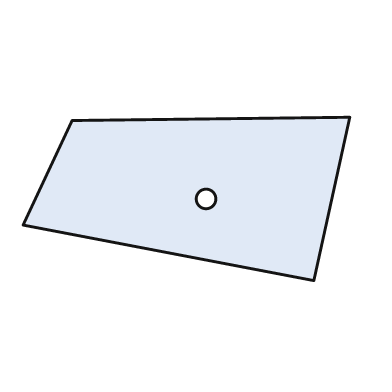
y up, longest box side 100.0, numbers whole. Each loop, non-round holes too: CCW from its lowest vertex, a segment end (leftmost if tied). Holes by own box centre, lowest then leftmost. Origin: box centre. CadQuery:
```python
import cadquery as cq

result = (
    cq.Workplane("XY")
    .moveTo(39.0, -25.0)
    .lineTo(50.0, 25.0)
    .lineTo(-35.0, 24.0)
    .lineTo(-50.0, -8.0)
    .close()
    .moveTo(6.0, 0.0)
    .circle(3.0)
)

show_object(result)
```